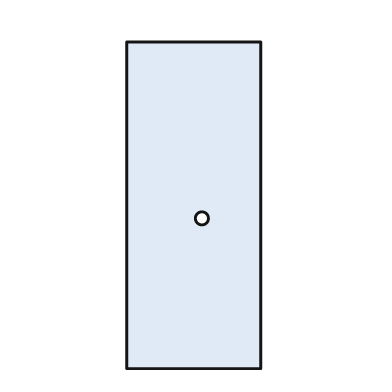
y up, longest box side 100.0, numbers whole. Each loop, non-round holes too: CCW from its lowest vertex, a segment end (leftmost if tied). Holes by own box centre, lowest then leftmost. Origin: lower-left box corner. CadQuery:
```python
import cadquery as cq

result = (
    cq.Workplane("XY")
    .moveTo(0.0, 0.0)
    .lineTo(41.0, 0.0)
    .lineTo(41.0, 100.0)
    .lineTo(0.0, 100.0)
    .close()
    .moveTo(23.0, 46.0)
    .circle(2.0)
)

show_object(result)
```